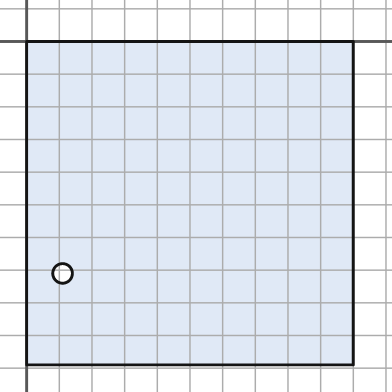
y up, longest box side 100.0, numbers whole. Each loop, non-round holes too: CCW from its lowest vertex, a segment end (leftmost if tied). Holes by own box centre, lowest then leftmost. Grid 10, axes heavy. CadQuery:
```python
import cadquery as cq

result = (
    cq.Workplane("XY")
    .moveTo(0.0, -99.0)
    .lineTo(100.0, -99.0)
    .lineTo(100.0, 0.0)
    .lineTo(0.0, 0.0)
    .close()
    .moveTo(11.0, -71.0)
    .circle(3.0)
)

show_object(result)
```